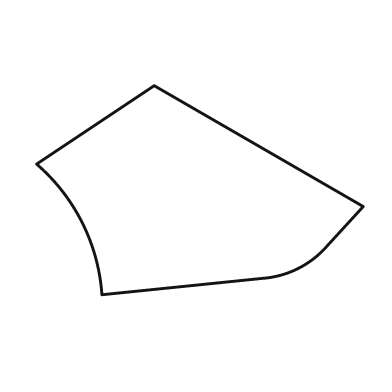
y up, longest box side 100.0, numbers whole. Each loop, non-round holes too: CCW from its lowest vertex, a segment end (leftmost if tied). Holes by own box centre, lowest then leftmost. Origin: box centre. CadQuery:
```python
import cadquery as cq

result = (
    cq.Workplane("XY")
    .moveTo(-30.0, -32.0)
    .lineTo(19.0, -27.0)
    .threePointArc((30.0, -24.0), (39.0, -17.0))
    .lineTo(50.0, -5.0)
    .lineTo(-14.0, 32.0)
    .lineTo(-50.0, 8.0)
    .threePointArc((-36.0, -10.0), (-30.0, -32.0))
    .close()
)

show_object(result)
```